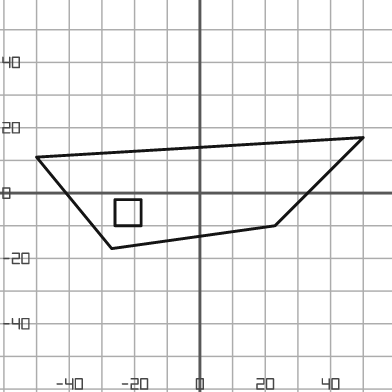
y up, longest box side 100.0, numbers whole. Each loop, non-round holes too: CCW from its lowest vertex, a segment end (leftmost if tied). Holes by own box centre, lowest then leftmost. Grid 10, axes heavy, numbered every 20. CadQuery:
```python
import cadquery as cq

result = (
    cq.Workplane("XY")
    .moveTo(-27.0, -17.0)
    .lineTo(23.0, -10.0)
    .lineTo(50.0, 17.0)
    .lineTo(-50.0, 11.0)
    .close()
    .moveTo(-26.0, -10.0)
    .lineTo(-18.0, -10.0)
    .lineTo(-18.0, -2.0)
    .lineTo(-26.0, -2.0)
    .close()
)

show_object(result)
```